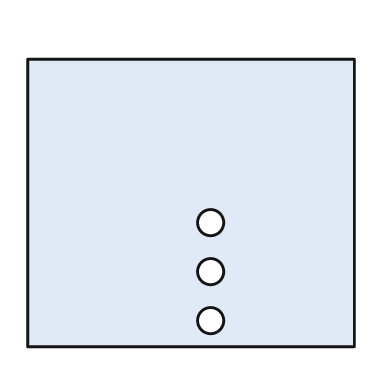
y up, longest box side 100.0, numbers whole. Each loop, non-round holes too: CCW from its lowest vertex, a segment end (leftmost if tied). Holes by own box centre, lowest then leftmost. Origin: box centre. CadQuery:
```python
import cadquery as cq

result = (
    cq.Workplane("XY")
    .moveTo(-50.0, -44.0)
    .lineTo(50.0, -44.0)
    .lineTo(50.0, 44.0)
    .lineTo(-50.0, 44.0)
    .close()
    .moveTo(6.0, -36.0)
    .circle(4.0)
    .moveTo(6.0, -21.0)
    .circle(4.0)
    .moveTo(6.0, -6.0)
    .circle(4.0)
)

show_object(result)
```